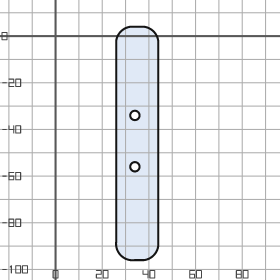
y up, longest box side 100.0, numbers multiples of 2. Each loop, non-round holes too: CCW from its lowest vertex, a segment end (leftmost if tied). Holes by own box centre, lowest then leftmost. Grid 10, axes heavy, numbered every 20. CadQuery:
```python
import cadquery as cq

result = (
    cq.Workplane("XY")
    .moveTo(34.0, -96.0)
    .lineTo(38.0, -96.0)
    .threePointArc((42.0, -94.0), (44.0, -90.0))
    .lineTo(44.0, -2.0)
    .threePointArc((42.0, 2.0), (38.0, 4.0))
    .lineTo(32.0, 4.0)
    .threePointArc((28.0, 2.0), (26.0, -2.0))
    .lineTo(26.0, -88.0)
    .threePointArc((28.0, -94.0), (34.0, -96.0))
    .close()
    .moveTo(34.0, -56.0)
    .circle(2.0)
    .moveTo(34.0, -34.0)
    .circle(2.0)
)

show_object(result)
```